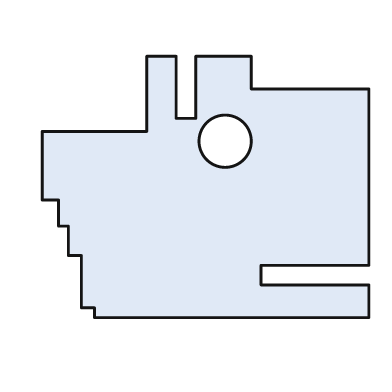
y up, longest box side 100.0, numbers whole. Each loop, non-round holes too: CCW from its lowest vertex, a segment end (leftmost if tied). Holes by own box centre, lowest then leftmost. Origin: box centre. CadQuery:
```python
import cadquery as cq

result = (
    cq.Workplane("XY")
    .moveTo(-34.0, -40.0)
    .lineTo(50.0, -40.0)
    .lineTo(50.0, -30.0)
    .lineTo(17.0, -30.0)
    .lineTo(17.0, -24.0)
    .lineTo(50.0, -24.0)
    .lineTo(50.0, 30.0)
    .lineTo(14.0, 30.0)
    .lineTo(14.0, 40.0)
    .lineTo(-3.0, 40.0)
    .lineTo(-3.0, 21.0)
    .lineTo(-9.0, 21.0)
    .lineTo(-9.0, 40.0)
    .lineTo(-18.0, 40.0)
    .lineTo(-18.0, 17.0)
    .lineTo(-50.0, 17.0)
    .lineTo(-50.0, -4.0)
    .lineTo(-45.0, -4.0)
    .lineTo(-45.0, -12.0)
    .lineTo(-42.0, -12.0)
    .lineTo(-42.0, -21.0)
    .lineTo(-38.0, -21.0)
    .lineTo(-38.0, -37.0)
    .lineTo(-34.0, -37.0)
    .close()
    .moveTo(6.0, 14.0)
    .circle(8.0)
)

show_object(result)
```